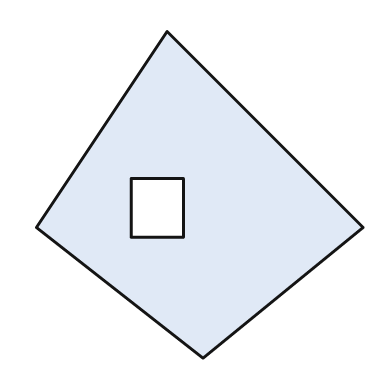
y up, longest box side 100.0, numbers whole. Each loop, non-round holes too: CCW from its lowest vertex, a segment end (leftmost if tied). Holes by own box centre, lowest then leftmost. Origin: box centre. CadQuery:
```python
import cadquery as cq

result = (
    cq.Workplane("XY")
    .moveTo(1.0, -50.0)
    .lineTo(50.0, -10.0)
    .lineTo(-10.0, 50.0)
    .lineTo(-50.0, -10.0)
    .close()
    .moveTo(-21.0, -13.0)
    .lineTo(-5.0, -13.0)
    .lineTo(-5.0, 5.0)
    .lineTo(-21.0, 5.0)
    .close()
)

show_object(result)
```